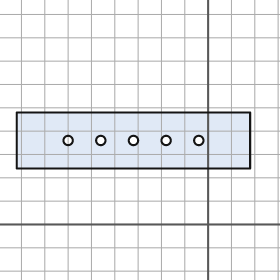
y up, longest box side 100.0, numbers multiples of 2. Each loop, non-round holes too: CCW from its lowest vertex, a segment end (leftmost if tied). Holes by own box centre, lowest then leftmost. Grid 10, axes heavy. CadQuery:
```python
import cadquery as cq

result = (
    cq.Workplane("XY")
    .moveTo(-82.0, 24.0)
    .lineTo(18.0, 24.0)
    .lineTo(18.0, 48.0)
    .lineTo(-82.0, 48.0)
    .close()
    .moveTo(-60.0, 36.0)
    .circle(2.0)
    .moveTo(-46.0, 36.0)
    .circle(2.0)
    .moveTo(-32.0, 36.0)
    .circle(2.0)
    .moveTo(-18.0, 36.0)
    .circle(2.0)
    .moveTo(-4.0, 36.0)
    .circle(2.0)
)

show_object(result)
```